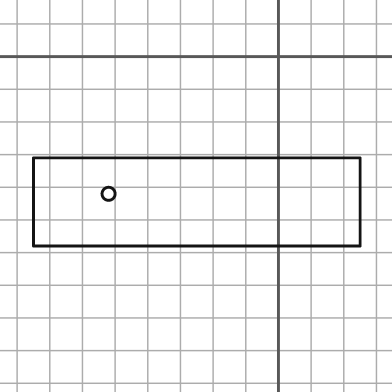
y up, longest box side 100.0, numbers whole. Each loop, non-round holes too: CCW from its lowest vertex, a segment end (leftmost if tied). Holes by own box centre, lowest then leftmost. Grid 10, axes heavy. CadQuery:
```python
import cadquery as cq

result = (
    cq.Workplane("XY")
    .moveTo(-75.0, -58.0)
    .lineTo(25.0, -58.0)
    .lineTo(25.0, -31.0)
    .lineTo(-75.0, -31.0)
    .close()
    .moveTo(-52.0, -42.0)
    .circle(2.0)
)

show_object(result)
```